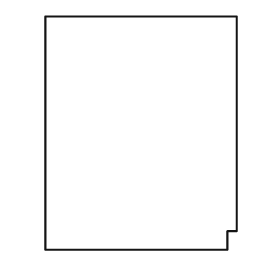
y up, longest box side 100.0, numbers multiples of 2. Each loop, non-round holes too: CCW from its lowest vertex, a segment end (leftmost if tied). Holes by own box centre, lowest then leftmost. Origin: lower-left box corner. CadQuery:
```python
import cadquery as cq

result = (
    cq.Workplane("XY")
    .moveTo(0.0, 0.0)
    .lineTo(78.0, 0.0)
    .lineTo(78.0, 8.0)
    .lineTo(82.0, 8.0)
    .lineTo(82.0, 100.0)
    .lineTo(0.0, 100.0)
    .close()
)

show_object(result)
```